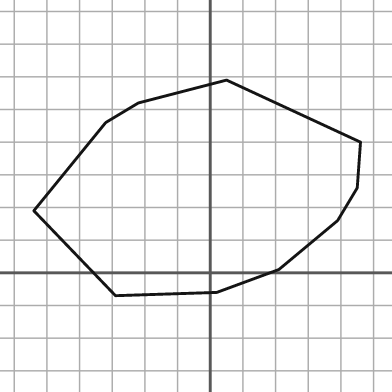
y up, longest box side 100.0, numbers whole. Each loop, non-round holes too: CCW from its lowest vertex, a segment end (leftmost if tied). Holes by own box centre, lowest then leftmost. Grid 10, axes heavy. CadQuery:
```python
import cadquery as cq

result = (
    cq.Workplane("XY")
    .moveTo(-29.0, -7.0)
    .lineTo(2.0, -6.0)
    .lineTo(21.0, 1.0)
    .lineTo(39.0, 16.0)
    .lineTo(45.0, 26.0)
    .lineTo(46.0, 40.0)
    .lineTo(5.0, 59.0)
    .lineTo(-22.0, 52.0)
    .lineTo(-32.0, 46.0)
    .lineTo(-54.0, 19.0)
    .close()
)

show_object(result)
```